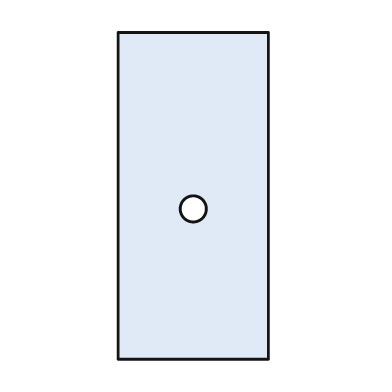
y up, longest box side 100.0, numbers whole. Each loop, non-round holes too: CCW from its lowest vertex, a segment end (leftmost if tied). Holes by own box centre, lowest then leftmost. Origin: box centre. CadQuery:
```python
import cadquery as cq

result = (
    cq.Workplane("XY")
    .moveTo(-23.0, -50.0)
    .lineTo(23.0, -50.0)
    .lineTo(23.0, 50.0)
    .lineTo(-23.0, 50.0)
    .close()
    .moveTo(0.0, -4.0)
    .circle(4.0)
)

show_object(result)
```